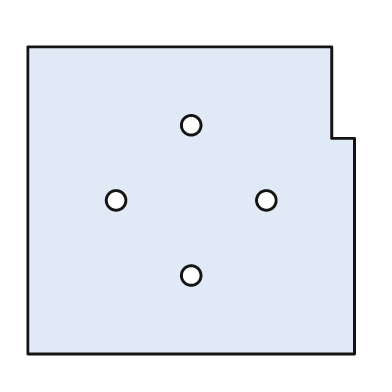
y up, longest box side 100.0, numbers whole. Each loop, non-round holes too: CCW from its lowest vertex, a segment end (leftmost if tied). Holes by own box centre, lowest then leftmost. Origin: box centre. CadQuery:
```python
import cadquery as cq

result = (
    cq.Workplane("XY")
    .moveTo(-50.0, -47.0)
    .lineTo(50.0, -47.0)
    .lineTo(50.0, 19.0)
    .lineTo(43.0, 19.0)
    .lineTo(43.0, 47.0)
    .lineTo(-50.0, 47.0)
    .close()
    .moveTo(0.0, -23.0)
    .circle(3.0)
    .moveTo(-23.0, 0.0)
    .circle(3.0)
    .moveTo(23.0, 0.0)
    .circle(3.0)
    .moveTo(0.0, 23.0)
    .circle(3.0)
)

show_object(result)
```